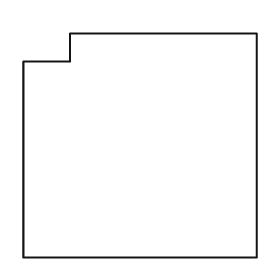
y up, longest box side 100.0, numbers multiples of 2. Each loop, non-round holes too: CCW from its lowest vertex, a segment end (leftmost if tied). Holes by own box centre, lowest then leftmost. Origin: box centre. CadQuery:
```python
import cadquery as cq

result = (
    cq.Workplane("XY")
    .moveTo(-50.0, -48.0)
    .lineTo(50.0, -48.0)
    .lineTo(50.0, 48.0)
    .lineTo(-30.0, 48.0)
    .lineTo(-30.0, 36.0)
    .lineTo(-50.0, 36.0)
    .close()
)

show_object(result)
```